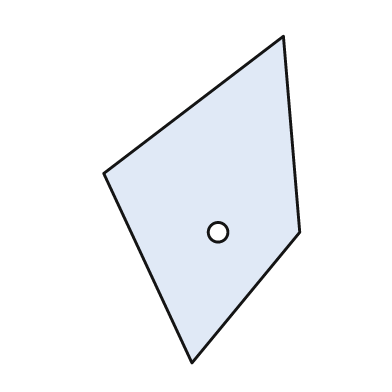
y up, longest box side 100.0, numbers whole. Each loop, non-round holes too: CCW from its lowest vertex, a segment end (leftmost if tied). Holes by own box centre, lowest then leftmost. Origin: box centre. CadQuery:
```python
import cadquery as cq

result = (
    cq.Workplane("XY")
    .moveTo(-3.0, -50.0)
    .lineTo(30.0, -10.0)
    .lineTo(25.0, 50.0)
    .lineTo(-30.0, 8.0)
    .close()
    .moveTo(5.0, -10.0)
    .circle(3.0)
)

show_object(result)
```